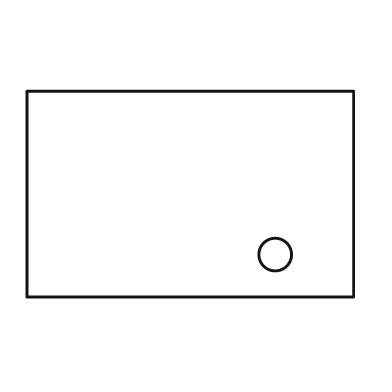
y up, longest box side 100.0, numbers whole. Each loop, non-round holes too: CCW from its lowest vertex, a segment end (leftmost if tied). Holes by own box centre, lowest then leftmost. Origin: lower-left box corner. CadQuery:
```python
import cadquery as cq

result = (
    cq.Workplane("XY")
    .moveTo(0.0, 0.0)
    .lineTo(100.0, 0.0)
    .lineTo(100.0, 63.0)
    .lineTo(0.0, 63.0)
    .close()
    .moveTo(76.0, 13.0)
    .circle(5.0)
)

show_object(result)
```